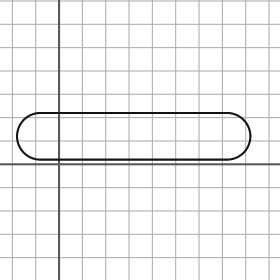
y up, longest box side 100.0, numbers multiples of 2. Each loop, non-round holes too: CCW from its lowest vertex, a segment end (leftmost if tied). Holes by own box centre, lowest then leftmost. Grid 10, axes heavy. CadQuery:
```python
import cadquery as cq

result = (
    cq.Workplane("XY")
    .moveTo(-8.0, 2.0)
    .lineTo(72.0, 2.0)
    .threePointArc((82.0, 12.0), (72.0, 22.0))
    .lineTo(-8.0, 22.0)
    .threePointArc((-18.0, 12.0), (-8.0, 2.0))
    .close()
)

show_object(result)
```